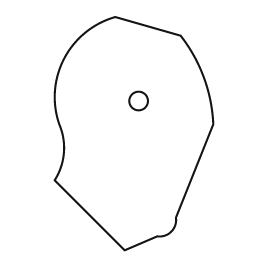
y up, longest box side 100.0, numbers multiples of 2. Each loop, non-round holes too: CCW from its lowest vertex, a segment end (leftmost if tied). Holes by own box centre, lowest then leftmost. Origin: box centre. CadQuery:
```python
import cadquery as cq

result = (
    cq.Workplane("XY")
    .moveTo(-4.0, -50.0)
    .lineTo(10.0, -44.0)
    .threePointArc((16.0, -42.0), (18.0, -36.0))
    .lineTo(34.0, 4.0)
    .threePointArc((30.0, 24.0), (20.0, 42.0))
    .lineTo(-8.0, 50.0)
    .threePointArc((-30.0, 32.0), (-32.0, 4.0))
    .threePointArc((-30.0, -8.0), (-34.0, -20.0))
    .close()
    .moveTo(2.0, 14.0)
    .circle(4.0)
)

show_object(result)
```